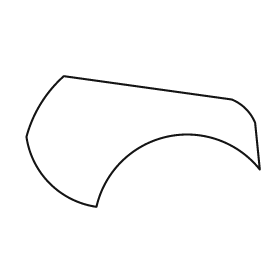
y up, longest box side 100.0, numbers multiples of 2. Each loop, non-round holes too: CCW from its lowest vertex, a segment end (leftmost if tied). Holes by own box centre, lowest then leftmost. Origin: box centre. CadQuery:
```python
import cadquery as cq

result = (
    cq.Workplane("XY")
    .moveTo(-20.0, -28.0)
    .threePointArc((10.0, 2.0), (50.0, -12.0))
    .lineTo(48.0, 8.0)
    .threePointArc((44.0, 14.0), (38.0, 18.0))
    .lineTo(-34.0, 28.0)
    .threePointArc((-44.0, 16.0), (-50.0, 2.0))
    .threePointArc((-40.0, -18.0), (-20.0, -28.0))
    .close()
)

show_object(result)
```